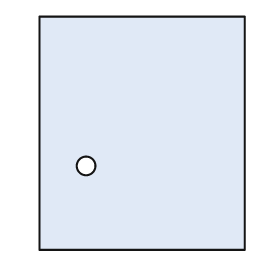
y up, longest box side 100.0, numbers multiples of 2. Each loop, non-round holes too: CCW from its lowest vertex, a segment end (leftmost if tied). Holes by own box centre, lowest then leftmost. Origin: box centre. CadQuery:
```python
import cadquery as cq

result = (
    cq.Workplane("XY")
    .moveTo(-44.0, -50.0)
    .lineTo(44.0, -50.0)
    .lineTo(44.0, 50.0)
    .lineTo(-44.0, 50.0)
    .close()
    .moveTo(-24.0, -14.0)
    .circle(4.0)
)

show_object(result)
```